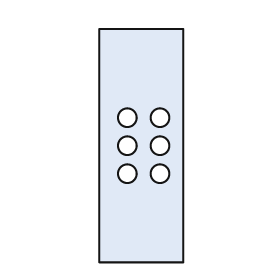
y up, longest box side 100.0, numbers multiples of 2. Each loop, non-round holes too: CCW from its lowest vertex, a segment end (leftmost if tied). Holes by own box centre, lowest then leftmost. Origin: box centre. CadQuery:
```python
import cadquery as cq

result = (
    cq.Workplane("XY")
    .moveTo(-18.0, -50.0)
    .lineTo(18.0, -50.0)
    .lineTo(18.0, 50.0)
    .lineTo(-18.0, 50.0)
    .close()
    .moveTo(-6.0, -12.0)
    .circle(4.0)
    .moveTo(8.0, -12.0)
    .circle(4.0)
    .moveTo(-6.0, 0.0)
    .circle(4.0)
    .moveTo(8.0, 0.0)
    .circle(4.0)
    .moveTo(-6.0, 12.0)
    .circle(4.0)
    .moveTo(8.0, 12.0)
    .circle(4.0)
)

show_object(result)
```